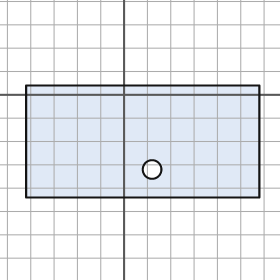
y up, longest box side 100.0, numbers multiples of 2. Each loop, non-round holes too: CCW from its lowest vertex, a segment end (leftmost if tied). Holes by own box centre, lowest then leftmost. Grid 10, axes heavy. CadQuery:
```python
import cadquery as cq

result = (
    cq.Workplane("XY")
    .moveTo(-42.0, -44.0)
    .lineTo(58.0, -44.0)
    .lineTo(58.0, 4.0)
    .lineTo(-42.0, 4.0)
    .close()
    .moveTo(12.0, -32.0)
    .circle(4.0)
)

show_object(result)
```